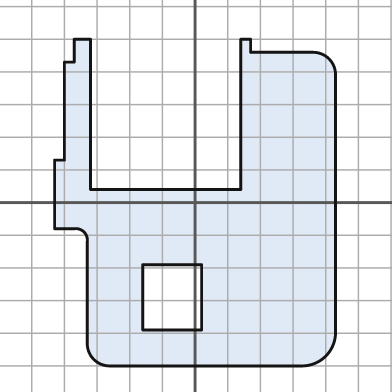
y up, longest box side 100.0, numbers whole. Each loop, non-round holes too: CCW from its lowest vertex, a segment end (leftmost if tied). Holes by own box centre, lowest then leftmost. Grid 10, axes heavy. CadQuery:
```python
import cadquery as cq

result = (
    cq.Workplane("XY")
    .moveTo(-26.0, -50.0)
    .lineTo(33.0, -50.0)
    .threePointArc((40.0, -47.0), (43.0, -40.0))
    .lineTo(43.0, 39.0)
    .threePointArc((41.0, 44.0), (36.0, 46.0))
    .lineTo(17.0, 46.0)
    .lineTo(17.0, 50.0)
    .lineTo(14.0, 50.0)
    .lineTo(14.0, 4.0)
    .lineTo(-32.0, 4.0)
    .lineTo(-32.0, 50.0)
    .lineTo(-37.0, 50.0)
    .lineTo(-37.0, 43.0)
    .lineTo(-40.0, 43.0)
    .lineTo(-40.0, 13.0)
    .lineTo(-43.0, 13.0)
    .lineTo(-43.0, -8.0)
    .lineTo(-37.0, -8.0)
    .threePointArc((-34.0, -9.0), (-33.0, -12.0))
    .lineTo(-33.0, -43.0)
    .threePointArc((-31.0, -48.0), (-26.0, -50.0))
    .close()
    .moveTo(-16.0, -39.0)
    .lineTo(2.0, -39.0)
    .lineTo(2.0, -19.0)
    .lineTo(-16.0, -19.0)
    .close()
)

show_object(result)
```